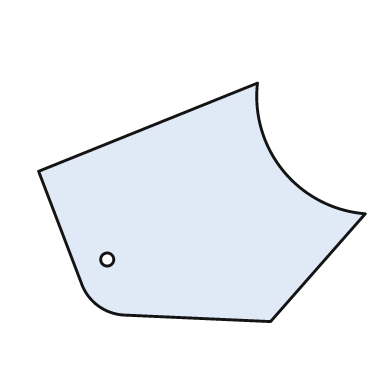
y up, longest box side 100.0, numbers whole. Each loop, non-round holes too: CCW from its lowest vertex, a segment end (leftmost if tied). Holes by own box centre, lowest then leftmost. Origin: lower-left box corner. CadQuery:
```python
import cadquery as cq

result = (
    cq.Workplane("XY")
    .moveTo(71.0, 0.0)
    .lineTo(100.0, 33.0)
    .threePointArc((75.0, 46.0), (67.0, 73.0))
    .lineTo(0.0, 46.0)
    .lineTo(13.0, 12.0)
    .threePointArc((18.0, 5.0), (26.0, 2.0))
    .close()
    .moveTo(21.0, 19.0)
    .circle(2.0)
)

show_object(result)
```